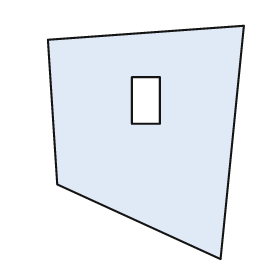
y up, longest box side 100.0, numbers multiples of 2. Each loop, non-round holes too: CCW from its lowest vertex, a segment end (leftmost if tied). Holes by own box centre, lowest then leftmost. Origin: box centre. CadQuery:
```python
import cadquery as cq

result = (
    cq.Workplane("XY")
    .moveTo(32.0, -50.0)
    .lineTo(42.0, 50.0)
    .lineTo(-42.0, 44.0)
    .lineTo(-38.0, -18.0)
    .close()
    .moveTo(-6.0, 8.0)
    .lineTo(6.0, 8.0)
    .lineTo(6.0, 28.0)
    .lineTo(-6.0, 28.0)
    .close()
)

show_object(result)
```